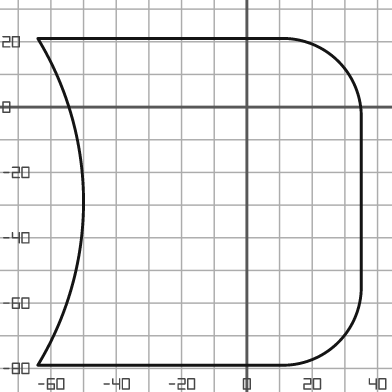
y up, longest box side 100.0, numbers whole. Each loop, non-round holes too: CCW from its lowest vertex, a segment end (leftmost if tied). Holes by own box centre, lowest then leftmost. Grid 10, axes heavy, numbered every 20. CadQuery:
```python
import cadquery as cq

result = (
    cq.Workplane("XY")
    .moveTo(-64.0, -79.0)
    .lineTo(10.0, -79.0)
    .threePointArc((28.0, -72.0), (35.0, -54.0))
    .lineTo(35.0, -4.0)
    .threePointArc((28.0, 14.0), (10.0, 21.0))
    .lineTo(-64.0, 21.0)
    .threePointArc((-50.0, -29.0), (-64.0, -79.0))
    .close()
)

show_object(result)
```